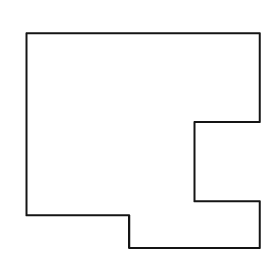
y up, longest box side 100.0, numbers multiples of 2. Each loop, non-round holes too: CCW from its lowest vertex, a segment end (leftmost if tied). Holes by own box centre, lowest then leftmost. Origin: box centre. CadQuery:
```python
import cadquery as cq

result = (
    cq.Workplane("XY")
    .moveTo(-6.0, -46.0)
    .lineTo(50.0, -46.0)
    .lineTo(50.0, -26.0)
    .lineTo(22.0, -26.0)
    .lineTo(22.0, 8.0)
    .lineTo(50.0, 8.0)
    .lineTo(50.0, 46.0)
    .lineTo(-50.0, 46.0)
    .lineTo(-50.0, -32.0)
    .lineTo(-6.0, -32.0)
    .close()
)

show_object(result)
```